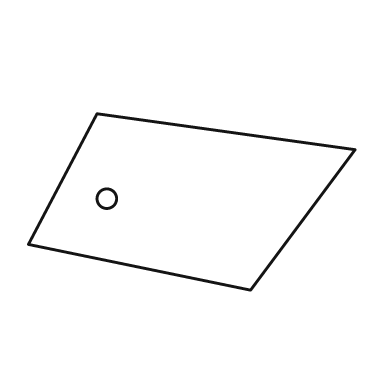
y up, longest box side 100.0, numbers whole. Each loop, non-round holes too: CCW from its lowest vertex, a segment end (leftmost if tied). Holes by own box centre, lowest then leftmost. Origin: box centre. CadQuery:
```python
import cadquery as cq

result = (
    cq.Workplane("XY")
    .moveTo(18.0, -27.0)
    .lineTo(50.0, 16.0)
    .lineTo(-29.0, 27.0)
    .lineTo(-50.0, -13.0)
    .close()
    .moveTo(-26.0, 1.0)
    .circle(3.0)
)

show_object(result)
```